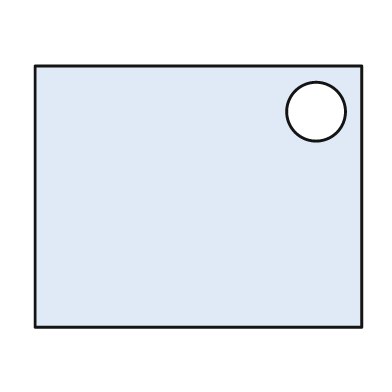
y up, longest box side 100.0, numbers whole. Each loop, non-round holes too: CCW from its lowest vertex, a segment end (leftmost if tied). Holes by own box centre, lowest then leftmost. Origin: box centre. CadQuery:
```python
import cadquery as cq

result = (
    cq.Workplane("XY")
    .moveTo(-50.0, -40.0)
    .lineTo(50.0, -40.0)
    .lineTo(50.0, 40.0)
    .lineTo(-50.0, 40.0)
    .close()
    .moveTo(36.0, 26.0)
    .circle(9.0)
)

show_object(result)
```